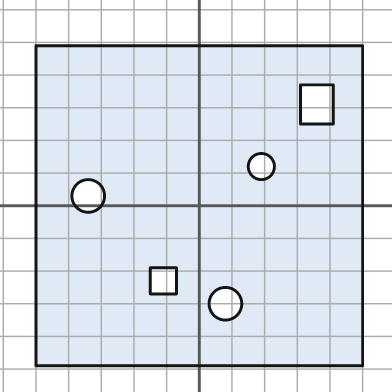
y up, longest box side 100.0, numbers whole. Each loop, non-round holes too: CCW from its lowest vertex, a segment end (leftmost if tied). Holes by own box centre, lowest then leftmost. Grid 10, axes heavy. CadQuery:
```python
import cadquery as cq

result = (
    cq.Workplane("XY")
    .moveTo(-50.0, -49.0)
    .lineTo(50.0, -49.0)
    .lineTo(50.0, 49.0)
    .lineTo(-50.0, 49.0)
    .close()
    .moveTo(8.0, -30.0)
    .circle(5.0)
    .moveTo(-15.0, -27.0)
    .lineTo(-7.0, -27.0)
    .lineTo(-7.0, -19.0)
    .lineTo(-15.0, -19.0)
    .close()
    .moveTo(-34.0, 3.0)
    .circle(5.0)
    .moveTo(19.0, 12.0)
    .circle(4.0)
    .moveTo(31.0, 25.0)
    .lineTo(41.0, 25.0)
    .lineTo(41.0, 37.0)
    .lineTo(31.0, 37.0)
    .close()
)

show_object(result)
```